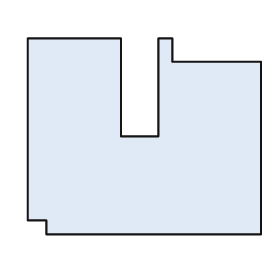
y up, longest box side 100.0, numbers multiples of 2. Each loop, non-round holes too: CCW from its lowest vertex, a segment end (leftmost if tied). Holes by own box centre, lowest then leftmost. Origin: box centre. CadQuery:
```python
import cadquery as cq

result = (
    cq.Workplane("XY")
    .moveTo(-42.0, -42.0)
    .lineTo(50.0, -42.0)
    .lineTo(50.0, 32.0)
    .lineTo(12.0, 32.0)
    .lineTo(12.0, 42.0)
    .lineTo(6.0, 42.0)
    .lineTo(6.0, 0.0)
    .lineTo(-10.0, 0.0)
    .lineTo(-10.0, 42.0)
    .lineTo(-50.0, 42.0)
    .lineTo(-50.0, -36.0)
    .lineTo(-42.0, -36.0)
    .close()
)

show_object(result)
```